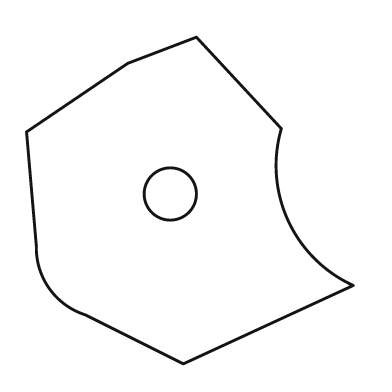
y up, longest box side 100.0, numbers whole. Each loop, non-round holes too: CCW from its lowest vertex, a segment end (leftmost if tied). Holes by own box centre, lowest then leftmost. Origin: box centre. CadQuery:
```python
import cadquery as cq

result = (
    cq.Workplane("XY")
    .moveTo(-2.0, -50.0)
    .lineTo(50.0, -26.0)
    .threePointArc((30.0, -6.0), (28.0, 22.0))
    .lineTo(2.0, 50.0)
    .lineTo(-19.0, 42.0)
    .lineTo(-50.0, 21.0)
    .lineTo(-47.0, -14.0)
    .threePointArc((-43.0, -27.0), (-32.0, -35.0))
    .close()
    .moveTo(-6.0, 2.0)
    .circle(8.0)
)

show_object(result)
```